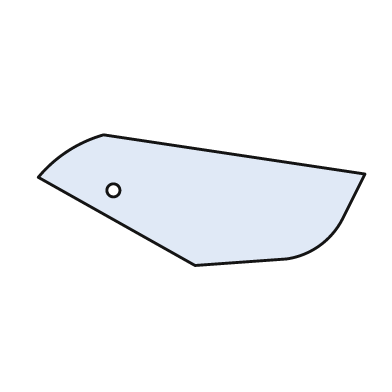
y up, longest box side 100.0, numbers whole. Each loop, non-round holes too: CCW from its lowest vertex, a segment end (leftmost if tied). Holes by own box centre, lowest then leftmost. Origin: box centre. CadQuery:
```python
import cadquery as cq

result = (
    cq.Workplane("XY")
    .moveTo(-2.0, -20.0)
    .lineTo(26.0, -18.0)
    .threePointArc((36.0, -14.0), (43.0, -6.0))
    .lineTo(50.0, 8.0)
    .lineTo(-30.0, 20.0)
    .threePointArc((-41.0, 15.0), (-50.0, 7.0))
    .close()
    .moveTo(-27.0, 3.0)
    .circle(2.0)
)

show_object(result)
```